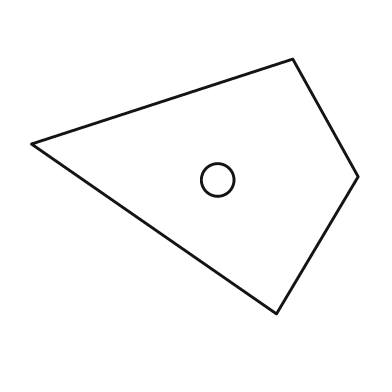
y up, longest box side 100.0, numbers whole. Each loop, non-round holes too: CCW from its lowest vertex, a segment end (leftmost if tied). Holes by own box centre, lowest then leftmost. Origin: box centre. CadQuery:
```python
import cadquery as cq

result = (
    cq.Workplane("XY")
    .moveTo(25.0, -39.0)
    .lineTo(50.0, 3.0)
    .lineTo(30.0, 39.0)
    .lineTo(-50.0, 13.0)
    .close()
    .moveTo(7.0, 2.0)
    .circle(5.0)
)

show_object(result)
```